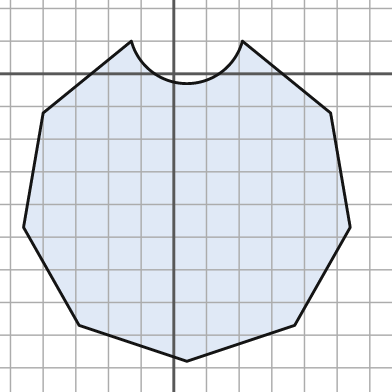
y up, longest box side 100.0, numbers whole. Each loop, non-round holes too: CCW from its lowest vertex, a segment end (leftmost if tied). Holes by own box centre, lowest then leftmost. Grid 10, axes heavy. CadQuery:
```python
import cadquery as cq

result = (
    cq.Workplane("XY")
    .moveTo(4.0, -88.0)
    .lineTo(37.0, -77.0)
    .lineTo(54.0, -47.0)
    .lineTo(48.0, -12.0)
    .lineTo(21.0, 10.0)
    .threePointArc((4.0, -3.0), (-13.0, 10.0))
    .lineTo(-40.0, -12.0)
    .lineTo(-46.0, -47.0)
    .lineTo(-29.0, -77.0)
    .close()
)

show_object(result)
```